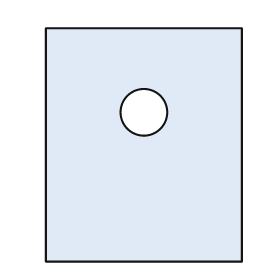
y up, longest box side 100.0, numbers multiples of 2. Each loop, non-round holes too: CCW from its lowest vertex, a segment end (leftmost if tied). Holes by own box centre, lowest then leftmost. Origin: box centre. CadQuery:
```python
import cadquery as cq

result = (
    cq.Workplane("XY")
    .moveTo(-42.0, -50.0)
    .lineTo(42.0, -50.0)
    .lineTo(42.0, 50.0)
    .lineTo(-42.0, 50.0)
    .close()
    .moveTo(0.0, 14.0)
    .circle(10.0)
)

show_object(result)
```